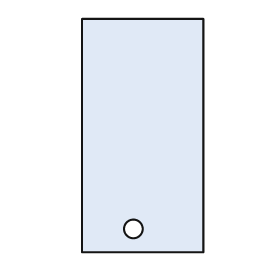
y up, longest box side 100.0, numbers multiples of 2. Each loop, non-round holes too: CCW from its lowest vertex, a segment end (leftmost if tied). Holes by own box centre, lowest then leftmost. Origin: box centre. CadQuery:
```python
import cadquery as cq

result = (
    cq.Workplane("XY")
    .moveTo(-26.0, -50.0)
    .lineTo(26.0, -50.0)
    .lineTo(26.0, 50.0)
    .lineTo(-26.0, 50.0)
    .close()
    .moveTo(-4.0, -40.0)
    .circle(4.0)
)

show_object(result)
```